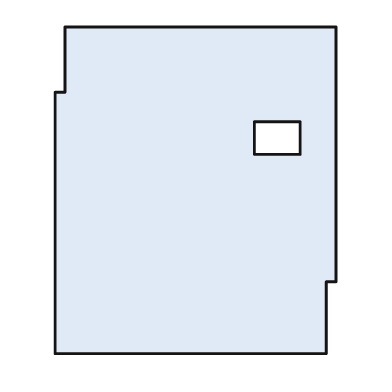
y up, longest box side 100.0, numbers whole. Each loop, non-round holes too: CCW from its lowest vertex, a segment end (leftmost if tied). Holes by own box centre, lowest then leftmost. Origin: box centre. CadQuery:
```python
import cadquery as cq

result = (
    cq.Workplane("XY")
    .moveTo(-43.0, -50.0)
    .lineTo(40.0, -50.0)
    .lineTo(40.0, -28.0)
    .lineTo(43.0, -28.0)
    .lineTo(43.0, 50.0)
    .lineTo(-40.0, 50.0)
    .lineTo(-40.0, 30.0)
    .lineTo(-43.0, 30.0)
    .close()
    .moveTo(18.0, 11.0)
    .lineTo(32.0, 11.0)
    .lineTo(32.0, 21.0)
    .lineTo(18.0, 21.0)
    .close()
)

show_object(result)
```